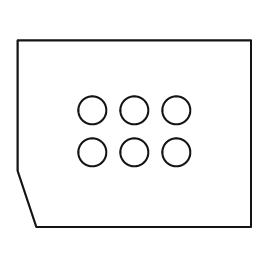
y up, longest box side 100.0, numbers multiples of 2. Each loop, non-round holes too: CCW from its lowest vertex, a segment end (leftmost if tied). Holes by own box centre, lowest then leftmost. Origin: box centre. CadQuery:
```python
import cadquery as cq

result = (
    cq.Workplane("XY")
    .moveTo(-42.0, -40.0)
    .lineTo(50.0, -40.0)
    .lineTo(50.0, 40.0)
    .lineTo(-50.0, 40.0)
    .lineTo(-50.0, -16.0)
    .close()
    .moveTo(-18.0, -8.0)
    .circle(6.0)
    .moveTo(0.0, -8.0)
    .circle(6.0)
    .moveTo(18.0, -8.0)
    .circle(6.0)
    .moveTo(-18.0, 10.0)
    .circle(6.0)
    .moveTo(0.0, 10.0)
    .circle(6.0)
    .moveTo(18.0, 10.0)
    .circle(6.0)
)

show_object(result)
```